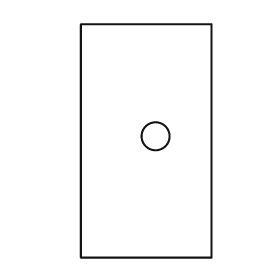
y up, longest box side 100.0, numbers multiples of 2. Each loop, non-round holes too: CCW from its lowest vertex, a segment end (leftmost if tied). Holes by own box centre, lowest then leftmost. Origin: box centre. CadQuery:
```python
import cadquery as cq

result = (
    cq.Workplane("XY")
    .moveTo(-28.0, -50.0)
    .lineTo(28.0, -50.0)
    .lineTo(28.0, 50.0)
    .lineTo(-28.0, 50.0)
    .close()
    .moveTo(4.0, 2.0)
    .circle(6.0)
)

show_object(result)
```